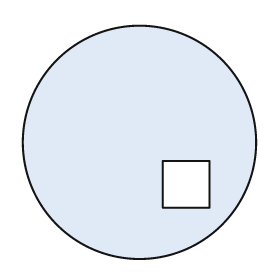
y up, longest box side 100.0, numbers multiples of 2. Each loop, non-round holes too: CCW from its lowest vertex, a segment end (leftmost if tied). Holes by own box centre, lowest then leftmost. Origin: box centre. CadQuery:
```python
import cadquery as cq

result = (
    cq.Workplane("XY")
    .moveTo(0.0, 0.0)
    .circle(50.0)
    .moveTo(10.0, -28.0)
    .lineTo(30.0, -28.0)
    .lineTo(30.0, -8.0)
    .lineTo(10.0, -8.0)
    .close()
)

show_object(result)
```